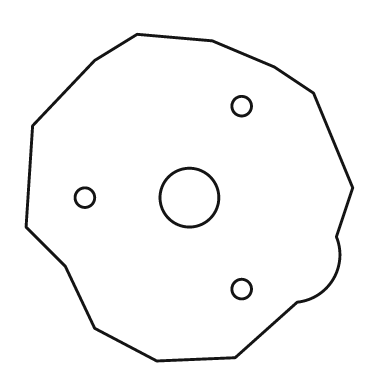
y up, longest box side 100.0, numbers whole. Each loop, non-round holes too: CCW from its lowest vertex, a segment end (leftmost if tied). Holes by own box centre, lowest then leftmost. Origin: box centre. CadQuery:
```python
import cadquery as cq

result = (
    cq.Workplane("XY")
    .moveTo(-10.0, -50.0)
    .lineTo(14.0, -49.0)
    .lineTo(33.0, -32.0)
    .threePointArc((44.0, -25.0), (45.0, -12.0))
    .lineTo(50.0, 3.0)
    .lineTo(38.0, 32.0)
    .lineTo(26.0, 40.0)
    .lineTo(7.0, 48.0)
    .lineTo(-16.0, 50.0)
    .lineTo(-29.0, 42.0)
    .lineTo(-48.0, 22.0)
    .lineTo(-50.0, -9.0)
    .lineTo(-38.0, -21.0)
    .lineTo(-29.0, -40.0)
    .close()
    .moveTo(16.0, -28.0)
    .circle(3.0)
    .moveTo(-32.0, 0.0)
    .circle(3.0)
    .moveTo(0.0, 0.0)
    .circle(9.0)
    .moveTo(16.0, 28.0)
    .circle(3.0)
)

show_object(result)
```